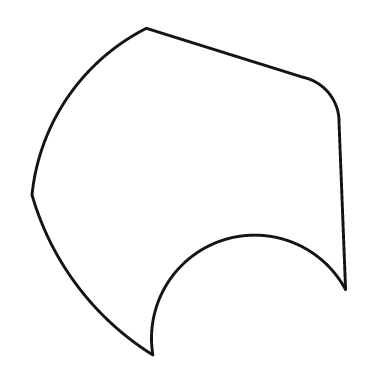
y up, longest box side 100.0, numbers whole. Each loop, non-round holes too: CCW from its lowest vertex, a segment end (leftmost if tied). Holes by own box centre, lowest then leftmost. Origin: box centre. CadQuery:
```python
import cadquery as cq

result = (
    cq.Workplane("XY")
    .moveTo(-11.0, -50.0)
    .threePointArc((10.0, -15.0), (48.0, -30.0))
    .lineTo(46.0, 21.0)
    .threePointArc((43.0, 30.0), (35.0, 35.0))
    .lineTo(-13.0, 50.0)
    .threePointArc((-37.0, 29.0), (-48.0, -1.0))
    .threePointArc((-34.0, -29.0), (-11.0, -50.0))
    .close()
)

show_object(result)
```